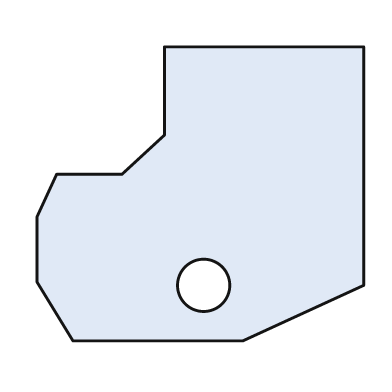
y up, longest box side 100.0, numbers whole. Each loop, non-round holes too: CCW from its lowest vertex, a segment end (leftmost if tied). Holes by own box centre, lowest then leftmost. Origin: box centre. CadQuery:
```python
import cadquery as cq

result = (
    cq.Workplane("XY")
    .moveTo(-39.0, -45.0)
    .lineTo(13.0, -45.0)
    .lineTo(50.0, -28.0)
    .lineTo(50.0, 45.0)
    .lineTo(-11.0, 45.0)
    .lineTo(-11.0, 18.0)
    .lineTo(-24.0, 6.0)
    .lineTo(-44.0, 6.0)
    .lineTo(-50.0, -7.0)
    .lineTo(-50.0, -27.0)
    .close()
    .moveTo(1.0, -28.0)
    .circle(8.0)
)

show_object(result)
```